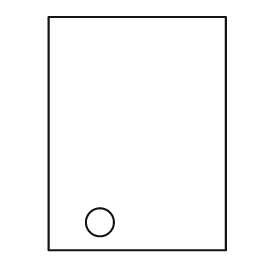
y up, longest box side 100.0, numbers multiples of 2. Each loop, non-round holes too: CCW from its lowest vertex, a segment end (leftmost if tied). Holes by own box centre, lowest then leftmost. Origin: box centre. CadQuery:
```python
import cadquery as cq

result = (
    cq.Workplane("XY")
    .moveTo(-38.0, -50.0)
    .lineTo(38.0, -50.0)
    .lineTo(38.0, 50.0)
    .lineTo(-38.0, 50.0)
    .close()
    .moveTo(-16.0, -38.0)
    .circle(6.0)
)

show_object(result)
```